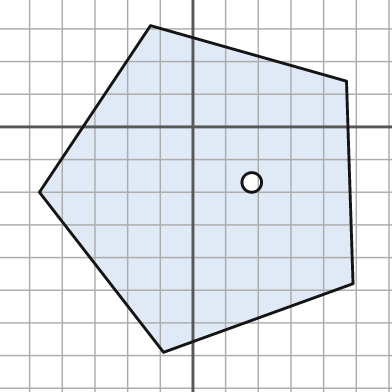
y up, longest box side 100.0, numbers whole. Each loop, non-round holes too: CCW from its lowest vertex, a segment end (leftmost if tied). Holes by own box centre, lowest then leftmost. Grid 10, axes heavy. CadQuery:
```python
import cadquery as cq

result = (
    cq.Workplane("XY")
    .moveTo(-9.0, -69.0)
    .lineTo(49.0, -48.0)
    .lineTo(47.0, 14.0)
    .lineTo(-13.0, 31.0)
    .lineTo(-47.0, -20.0)
    .close()
    .moveTo(18.0, -17.0)
    .circle(3.0)
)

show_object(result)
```